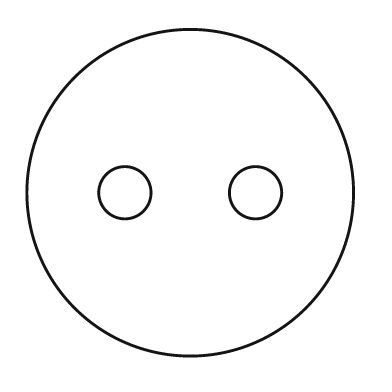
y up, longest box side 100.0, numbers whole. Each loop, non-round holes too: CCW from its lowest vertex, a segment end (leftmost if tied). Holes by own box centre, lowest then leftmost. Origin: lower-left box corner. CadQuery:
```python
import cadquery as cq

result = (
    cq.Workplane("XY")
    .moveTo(50.0, 50.0)
    .circle(50.0)
    .moveTo(30.0, 50.0)
    .circle(8.0)
    .moveTo(70.0, 50.0)
    .circle(8.0)
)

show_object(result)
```